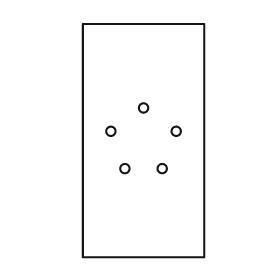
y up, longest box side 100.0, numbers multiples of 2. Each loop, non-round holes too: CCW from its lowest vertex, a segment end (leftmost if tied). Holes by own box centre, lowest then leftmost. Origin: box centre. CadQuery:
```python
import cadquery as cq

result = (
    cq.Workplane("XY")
    .moveTo(-26.0, -50.0)
    .lineTo(26.0, -50.0)
    .lineTo(26.0, 50.0)
    .lineTo(-26.0, 50.0)
    .close()
    .moveTo(-8.0, -12.0)
    .circle(2.0)
    .moveTo(8.0, -12.0)
    .circle(2.0)
    .moveTo(-14.0, 4.0)
    .circle(2.0)
    .moveTo(14.0, 4.0)
    .circle(2.0)
    .moveTo(0.0, 14.0)
    .circle(2.0)
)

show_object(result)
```